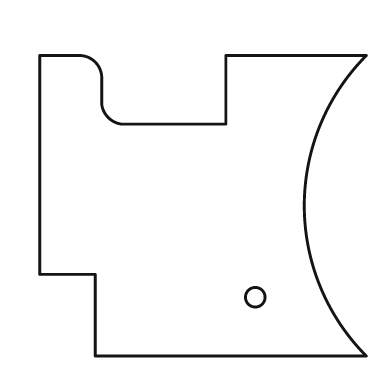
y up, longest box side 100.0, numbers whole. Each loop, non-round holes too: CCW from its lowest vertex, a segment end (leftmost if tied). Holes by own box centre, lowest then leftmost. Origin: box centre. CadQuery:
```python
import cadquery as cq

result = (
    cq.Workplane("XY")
    .moveTo(-33.0, -46.0)
    .lineTo(50.0, -46.0)
    .threePointArc((31.0, 0.0), (50.0, 46.0))
    .lineTo(7.0, 46.0)
    .lineTo(7.0, 25.0)
    .lineTo(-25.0, 25.0)
    .threePointArc((-29.0, 27.0), (-31.0, 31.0))
    .lineTo(-31.0, 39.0)
    .threePointArc((-33.0, 44.0), (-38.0, 46.0))
    .lineTo(-50.0, 46.0)
    .lineTo(-50.0, -21.0)
    .lineTo(-33.0, -21.0)
    .close()
    .moveTo(16.0, -28.0)
    .circle(3.0)
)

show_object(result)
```